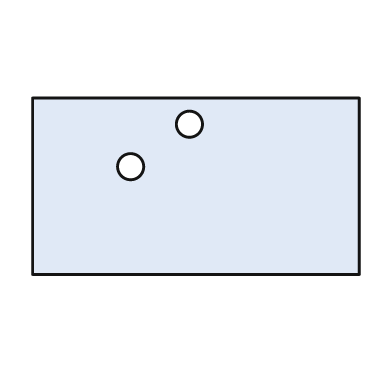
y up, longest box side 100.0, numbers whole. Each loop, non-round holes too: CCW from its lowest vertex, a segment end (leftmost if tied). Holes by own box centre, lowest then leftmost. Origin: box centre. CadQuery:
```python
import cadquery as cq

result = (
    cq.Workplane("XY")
    .moveTo(-50.0, -27.0)
    .lineTo(50.0, -27.0)
    .lineTo(50.0, 27.0)
    .lineTo(-50.0, 27.0)
    .close()
    .moveTo(-20.0, 6.0)
    .circle(4.0)
    .moveTo(-2.0, 19.0)
    .circle(4.0)
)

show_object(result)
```